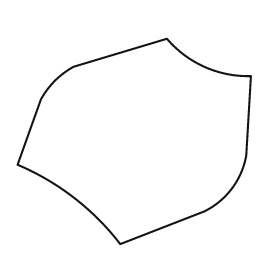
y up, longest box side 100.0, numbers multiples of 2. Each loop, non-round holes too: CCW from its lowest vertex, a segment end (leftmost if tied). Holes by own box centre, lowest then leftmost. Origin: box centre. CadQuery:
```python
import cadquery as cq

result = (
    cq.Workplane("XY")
    .moveTo(-6.0, -44.0)
    .lineTo(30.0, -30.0)
    .threePointArc((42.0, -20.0), (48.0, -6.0))
    .lineTo(50.0, 28.0)
    .threePointArc((30.0, 32.0), (14.0, 44.0))
    .lineTo(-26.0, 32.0)
    .threePointArc((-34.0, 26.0), (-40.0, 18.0))
    .lineTo(-50.0, -10.0)
    .threePointArc((-26.0, -24.0), (-6.0, -44.0))
    .close()
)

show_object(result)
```